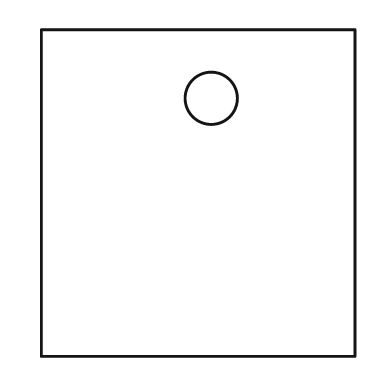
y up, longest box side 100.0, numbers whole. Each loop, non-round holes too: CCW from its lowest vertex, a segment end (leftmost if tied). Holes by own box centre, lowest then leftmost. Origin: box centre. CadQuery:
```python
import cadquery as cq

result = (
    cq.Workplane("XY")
    .moveTo(-48.0, -50.0)
    .lineTo(48.0, -50.0)
    .lineTo(48.0, 50.0)
    .lineTo(-48.0, 50.0)
    .close()
    .moveTo(4.0, 29.0)
    .circle(8.0)
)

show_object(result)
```